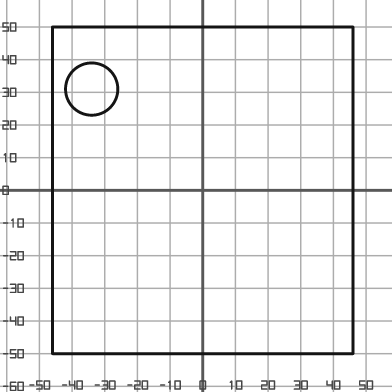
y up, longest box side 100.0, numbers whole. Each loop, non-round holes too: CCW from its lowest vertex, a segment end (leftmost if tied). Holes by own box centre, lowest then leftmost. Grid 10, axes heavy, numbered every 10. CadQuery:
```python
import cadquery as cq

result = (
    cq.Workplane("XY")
    .moveTo(-46.0, -50.0)
    .lineTo(46.0, -50.0)
    .lineTo(46.0, 50.0)
    .lineTo(-46.0, 50.0)
    .close()
    .moveTo(-34.0, 31.0)
    .circle(8.0)
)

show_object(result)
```